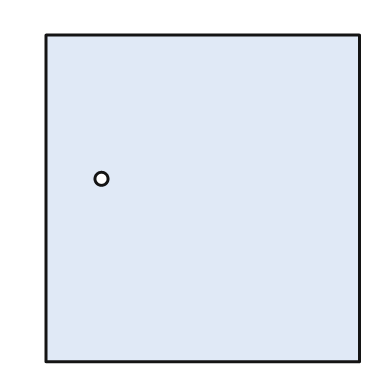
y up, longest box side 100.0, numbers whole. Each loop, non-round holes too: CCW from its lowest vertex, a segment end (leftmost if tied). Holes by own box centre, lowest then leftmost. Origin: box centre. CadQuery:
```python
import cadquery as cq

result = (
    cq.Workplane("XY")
    .moveTo(-48.0, -50.0)
    .lineTo(48.0, -50.0)
    .lineTo(48.0, 50.0)
    .lineTo(-48.0, 50.0)
    .close()
    .moveTo(-31.0, 6.0)
    .circle(2.0)
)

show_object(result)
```